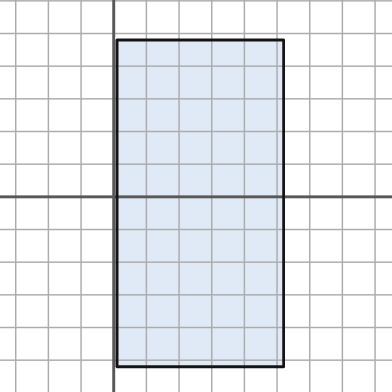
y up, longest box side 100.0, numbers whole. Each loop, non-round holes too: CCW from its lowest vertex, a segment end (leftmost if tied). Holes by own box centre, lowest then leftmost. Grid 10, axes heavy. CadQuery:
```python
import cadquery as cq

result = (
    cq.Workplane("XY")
    .moveTo(1.0, -52.0)
    .lineTo(52.0, -52.0)
    .lineTo(52.0, 48.0)
    .lineTo(1.0, 48.0)
    .close()
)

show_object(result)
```